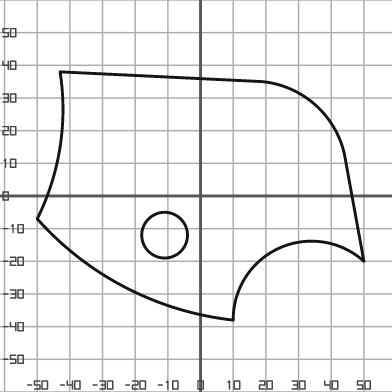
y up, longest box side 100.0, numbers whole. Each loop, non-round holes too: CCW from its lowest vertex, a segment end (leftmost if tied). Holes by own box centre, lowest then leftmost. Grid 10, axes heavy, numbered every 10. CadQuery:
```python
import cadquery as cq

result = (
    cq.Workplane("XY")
    .moveTo(10.0, -38.0)
    .threePointArc((24.0, -16.0), (50.0, -20.0))
    .lineTo(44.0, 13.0)
    .threePointArc((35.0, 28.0), (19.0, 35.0))
    .lineTo(-43.0, 38.0)
    .threePointArc((-43.0, 15.0), (-50.0, -7.0))
    .threePointArc((-23.0, -28.0), (10.0, -38.0))
    .close()
    .moveTo(-11.0, -12.0)
    .circle(7.0)
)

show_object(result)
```